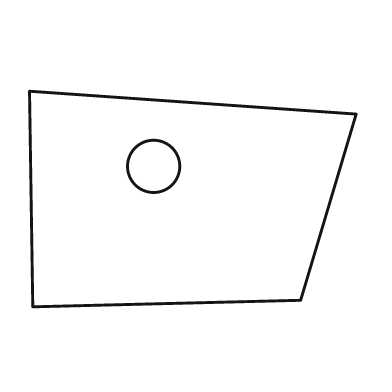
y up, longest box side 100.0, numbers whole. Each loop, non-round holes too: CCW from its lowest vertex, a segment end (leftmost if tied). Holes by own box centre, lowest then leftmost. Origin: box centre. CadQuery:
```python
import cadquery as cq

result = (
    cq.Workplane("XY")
    .moveTo(-49.0, -33.0)
    .lineTo(33.0, -31.0)
    .lineTo(50.0, 26.0)
    .lineTo(-50.0, 33.0)
    .close()
    .moveTo(-12.0, 10.0)
    .circle(8.0)
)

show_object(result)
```